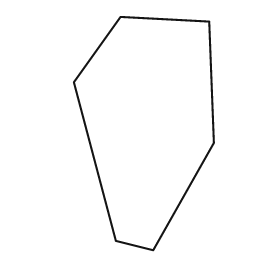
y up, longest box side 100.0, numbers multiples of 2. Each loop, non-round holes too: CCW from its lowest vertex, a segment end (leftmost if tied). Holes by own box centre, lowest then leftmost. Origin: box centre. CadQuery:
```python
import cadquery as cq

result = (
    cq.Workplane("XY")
    .moveTo(4.0, -50.0)
    .lineTo(30.0, -4.0)
    .lineTo(28.0, 48.0)
    .lineTo(-10.0, 50.0)
    .lineTo(-30.0, 22.0)
    .lineTo(-12.0, -46.0)
    .close()
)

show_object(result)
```